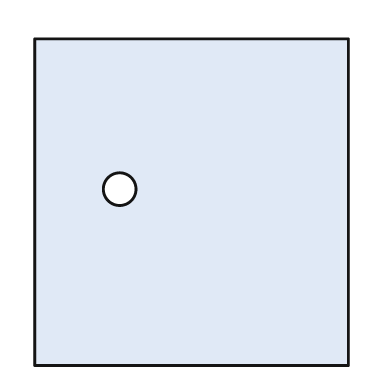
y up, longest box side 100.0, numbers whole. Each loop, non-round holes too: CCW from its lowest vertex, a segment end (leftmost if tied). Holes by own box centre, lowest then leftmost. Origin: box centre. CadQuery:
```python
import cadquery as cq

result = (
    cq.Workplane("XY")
    .moveTo(-48.0, -50.0)
    .lineTo(48.0, -50.0)
    .lineTo(48.0, 50.0)
    .lineTo(-48.0, 50.0)
    .close()
    .moveTo(-22.0, 4.0)
    .circle(5.0)
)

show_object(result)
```